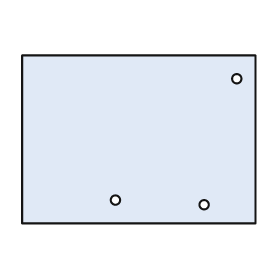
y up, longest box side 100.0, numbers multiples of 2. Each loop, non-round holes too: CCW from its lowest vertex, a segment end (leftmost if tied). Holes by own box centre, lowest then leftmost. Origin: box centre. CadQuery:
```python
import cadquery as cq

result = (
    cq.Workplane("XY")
    .moveTo(-50.0, -36.0)
    .lineTo(50.0, -36.0)
    .lineTo(50.0, 36.0)
    .lineTo(-50.0, 36.0)
    .close()
    .moveTo(28.0, -28.0)
    .circle(2.0)
    .moveTo(-10.0, -26.0)
    .circle(2.0)
    .moveTo(42.0, 26.0)
    .circle(2.0)
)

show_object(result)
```